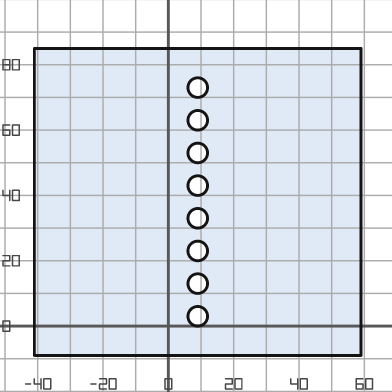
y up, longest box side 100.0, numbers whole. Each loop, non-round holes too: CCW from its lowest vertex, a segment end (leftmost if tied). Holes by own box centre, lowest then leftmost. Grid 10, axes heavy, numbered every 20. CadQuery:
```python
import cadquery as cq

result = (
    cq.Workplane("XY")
    .moveTo(-41.0, -9.0)
    .lineTo(59.0, -9.0)
    .lineTo(59.0, 85.0)
    .lineTo(-41.0, 85.0)
    .close()
    .moveTo(9.0, 3.0)
    .circle(3.0)
    .moveTo(9.0, 13.0)
    .circle(3.0)
    .moveTo(9.0, 23.0)
    .circle(3.0)
    .moveTo(9.0, 33.0)
    .circle(3.0)
    .moveTo(9.0, 43.0)
    .circle(3.0)
    .moveTo(9.0, 53.0)
    .circle(3.0)
    .moveTo(9.0, 63.0)
    .circle(3.0)
    .moveTo(9.0, 73.0)
    .circle(3.0)
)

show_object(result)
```